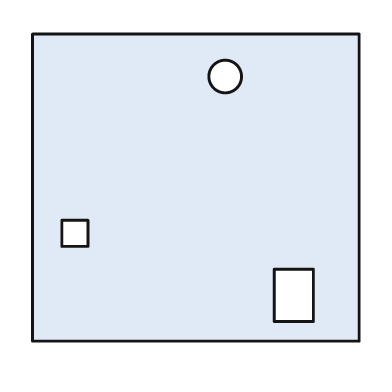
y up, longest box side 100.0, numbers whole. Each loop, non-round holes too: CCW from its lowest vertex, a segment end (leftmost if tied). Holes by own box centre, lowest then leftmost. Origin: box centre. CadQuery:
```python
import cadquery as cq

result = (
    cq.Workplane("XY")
    .moveTo(-50.0, -47.0)
    .lineTo(50.0, -47.0)
    .lineTo(50.0, 47.0)
    .lineTo(-50.0, 47.0)
    .close()
    .moveTo(24.0, -41.0)
    .lineTo(36.0, -41.0)
    .lineTo(36.0, -25.0)
    .lineTo(24.0, -25.0)
    .close()
    .moveTo(-41.0, -18.0)
    .lineTo(-33.0, -18.0)
    .lineTo(-33.0, -10.0)
    .lineTo(-41.0, -10.0)
    .close()
    .moveTo(9.0, 34.0)
    .circle(5.0)
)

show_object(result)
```